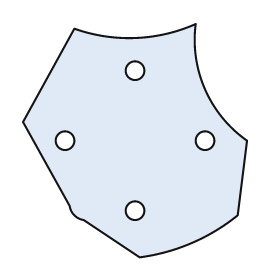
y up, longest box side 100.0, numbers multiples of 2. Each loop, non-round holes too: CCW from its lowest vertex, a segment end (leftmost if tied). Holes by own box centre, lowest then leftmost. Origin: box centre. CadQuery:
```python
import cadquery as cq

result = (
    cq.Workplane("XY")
    .moveTo(2.0, -50.0)
    .threePointArc((24.0, -44.0), (44.0, -32.0))
    .lineTo(48.0, 0.0)
    .threePointArc((30.0, 22.0), (26.0, 50.0))
    .threePointArc((0.0, 44.0), (-26.0, 48.0))
    .lineTo(-48.0, 8.0)
    .lineTo(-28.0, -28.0)
    .threePointArc((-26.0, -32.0), (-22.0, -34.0))
    .close()
    .moveTo(0.0, -30.0)
    .circle(4.0)
    .moveTo(-30.0, 0.0)
    .circle(4.0)
    .moveTo(30.0, 0.0)
    .circle(4.0)
    .moveTo(0.0, 30.0)
    .circle(4.0)
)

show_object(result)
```